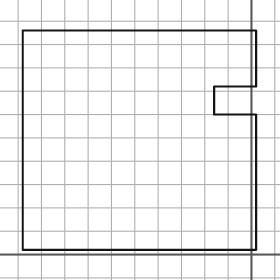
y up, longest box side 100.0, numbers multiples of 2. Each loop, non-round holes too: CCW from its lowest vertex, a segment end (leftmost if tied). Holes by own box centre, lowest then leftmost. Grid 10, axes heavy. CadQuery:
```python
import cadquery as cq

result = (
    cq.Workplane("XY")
    .moveTo(-98.0, 2.0)
    .lineTo(2.0, 2.0)
    .lineTo(2.0, 60.0)
    .lineTo(-16.0, 60.0)
    .lineTo(-16.0, 72.0)
    .lineTo(2.0, 72.0)
    .lineTo(2.0, 96.0)
    .lineTo(-98.0, 96.0)
    .close()
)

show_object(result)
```